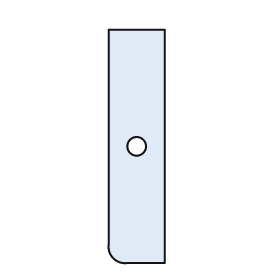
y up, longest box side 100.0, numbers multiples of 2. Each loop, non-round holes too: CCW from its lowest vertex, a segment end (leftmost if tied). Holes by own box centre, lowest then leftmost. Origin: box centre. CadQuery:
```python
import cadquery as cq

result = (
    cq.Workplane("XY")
    .moveTo(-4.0, -50.0)
    .lineTo(12.0, -50.0)
    .lineTo(12.0, 50.0)
    .lineTo(-12.0, 50.0)
    .lineTo(-12.0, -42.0)
    .threePointArc((-10.0, -48.0), (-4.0, -50.0))
    .close()
    .moveTo(0.0, 0.0)
    .circle(4.0)
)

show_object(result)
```